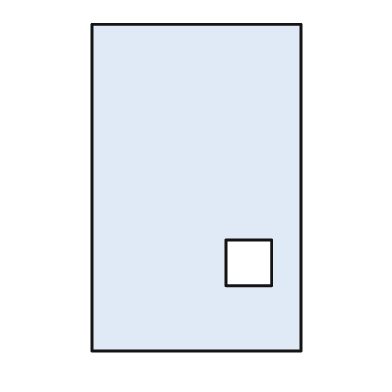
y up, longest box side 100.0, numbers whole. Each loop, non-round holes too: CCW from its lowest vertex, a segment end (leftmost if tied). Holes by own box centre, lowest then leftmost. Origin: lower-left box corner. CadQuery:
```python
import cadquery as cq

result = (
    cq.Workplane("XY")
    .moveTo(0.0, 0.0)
    .lineTo(64.0, 0.0)
    .lineTo(64.0, 100.0)
    .lineTo(0.0, 100.0)
    .close()
    .moveTo(41.0, 20.0)
    .lineTo(55.0, 20.0)
    .lineTo(55.0, 34.0)
    .lineTo(41.0, 34.0)
    .close()
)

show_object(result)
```